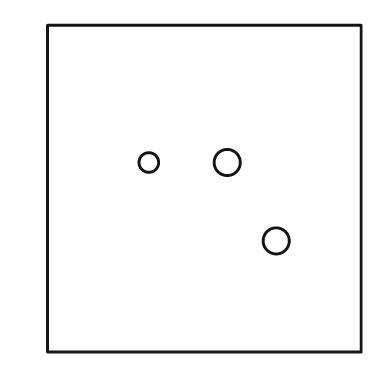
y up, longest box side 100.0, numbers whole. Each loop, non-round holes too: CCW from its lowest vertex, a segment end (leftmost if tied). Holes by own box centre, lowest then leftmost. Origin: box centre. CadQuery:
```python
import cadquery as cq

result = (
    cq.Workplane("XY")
    .moveTo(-48.0, -50.0)
    .lineTo(48.0, -50.0)
    .lineTo(48.0, 50.0)
    .lineTo(-48.0, 50.0)
    .close()
    .moveTo(22.0, -16.0)
    .circle(4.0)
    .moveTo(-17.0, 8.0)
    .circle(3.0)
    .moveTo(7.0, 8.0)
    .circle(4.0)
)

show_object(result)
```